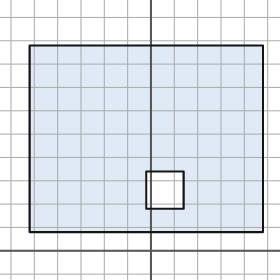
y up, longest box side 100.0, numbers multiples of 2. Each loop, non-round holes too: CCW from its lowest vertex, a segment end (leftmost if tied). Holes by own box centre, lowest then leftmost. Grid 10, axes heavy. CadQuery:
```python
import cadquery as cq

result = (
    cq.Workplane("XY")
    .moveTo(-52.0, 8.0)
    .lineTo(48.0, 8.0)
    .lineTo(48.0, 88.0)
    .lineTo(-52.0, 88.0)
    .close()
    .moveTo(-2.0, 18.0)
    .lineTo(14.0, 18.0)
    .lineTo(14.0, 34.0)
    .lineTo(-2.0, 34.0)
    .close()
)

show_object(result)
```